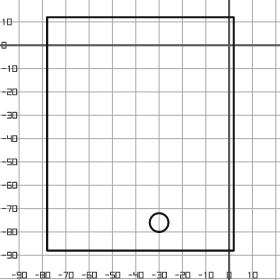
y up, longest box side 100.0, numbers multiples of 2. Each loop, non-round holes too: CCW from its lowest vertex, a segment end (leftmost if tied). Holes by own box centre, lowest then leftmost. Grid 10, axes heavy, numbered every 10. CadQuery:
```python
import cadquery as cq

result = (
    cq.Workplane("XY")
    .moveTo(-78.0, -88.0)
    .lineTo(2.0, -88.0)
    .lineTo(2.0, 12.0)
    .lineTo(-78.0, 12.0)
    .close()
    .moveTo(-30.0, -76.0)
    .circle(4.0)
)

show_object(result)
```